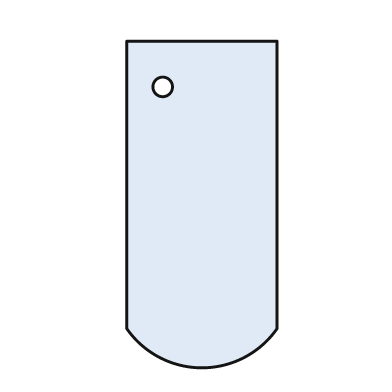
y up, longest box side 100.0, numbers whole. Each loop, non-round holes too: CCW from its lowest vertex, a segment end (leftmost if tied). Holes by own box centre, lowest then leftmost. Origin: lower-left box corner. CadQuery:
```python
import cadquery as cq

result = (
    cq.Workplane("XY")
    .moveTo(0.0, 12.0)
    .threePointArc((23.0, 0.0), (46.0, 12.0))
    .lineTo(46.0, 100.0)
    .lineTo(0.0, 100.0)
    .close()
    .moveTo(11.0, 86.0)
    .circle(3.0)
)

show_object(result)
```